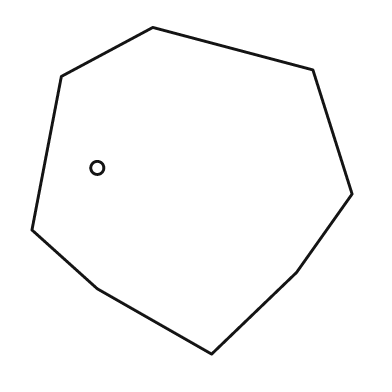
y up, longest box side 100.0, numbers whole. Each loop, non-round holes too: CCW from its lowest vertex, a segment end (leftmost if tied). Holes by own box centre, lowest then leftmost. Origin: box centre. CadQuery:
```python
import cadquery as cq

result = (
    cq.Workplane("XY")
    .moveTo(6.0, -50.0)
    .lineTo(32.0, -25.0)
    .lineTo(49.0, -1.0)
    .lineTo(37.0, 37.0)
    .lineTo(-12.0, 50.0)
    .lineTo(-40.0, 35.0)
    .lineTo(-49.0, -12.0)
    .lineTo(-29.0, -30.0)
    .close()
    .moveTo(-29.0, 7.0)
    .circle(2.0)
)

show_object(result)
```